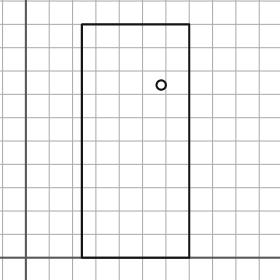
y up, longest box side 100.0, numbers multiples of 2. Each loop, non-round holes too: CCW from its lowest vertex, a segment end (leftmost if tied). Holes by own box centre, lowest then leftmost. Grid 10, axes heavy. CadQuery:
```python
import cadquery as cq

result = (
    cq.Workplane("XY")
    .moveTo(24.0, 0.0)
    .lineTo(70.0, 0.0)
    .lineTo(70.0, 100.0)
    .lineTo(24.0, 100.0)
    .close()
    .moveTo(58.0, 74.0)
    .circle(2.0)
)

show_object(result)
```